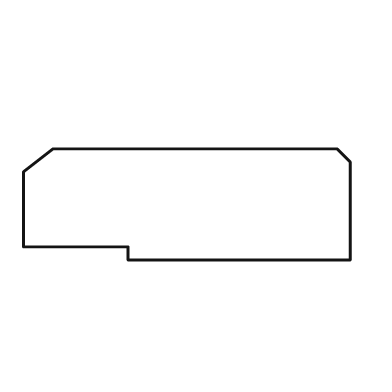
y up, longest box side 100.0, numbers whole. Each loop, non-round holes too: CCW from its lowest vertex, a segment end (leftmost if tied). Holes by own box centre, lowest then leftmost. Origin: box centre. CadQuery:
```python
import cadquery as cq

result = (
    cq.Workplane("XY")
    .moveTo(-18.0, -17.0)
    .lineTo(50.0, -17.0)
    .lineTo(50.0, 13.0)
    .lineTo(46.0, 17.0)
    .lineTo(-41.0, 17.0)
    .lineTo(-50.0, 10.0)
    .lineTo(-50.0, -13.0)
    .lineTo(-18.0, -13.0)
    .close()
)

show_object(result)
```